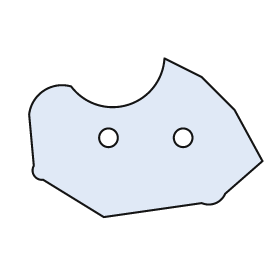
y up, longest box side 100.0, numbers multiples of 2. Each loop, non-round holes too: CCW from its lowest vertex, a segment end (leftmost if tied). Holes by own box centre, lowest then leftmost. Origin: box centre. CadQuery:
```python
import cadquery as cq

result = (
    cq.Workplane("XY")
    .moveTo(-18.0, -34.0)
    .lineTo(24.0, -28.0)
    .threePointArc((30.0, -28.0), (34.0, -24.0))
    .lineTo(50.0, -10.0)
    .lineTo(38.0, 12.0)
    .lineTo(24.0, 26.0)
    .lineTo(8.0, 34.0)
    .threePointArc((-8.0, 14.0), (-32.0, 22.0))
    .threePointArc((-44.0, 20.0), (-50.0, 10.0))
    .lineTo(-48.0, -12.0)
    .threePointArc((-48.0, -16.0), (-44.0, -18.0))
    .close()
    .moveTo(-16.0, 0.0)
    .circle(4.0)
    .moveTo(16.0, 0.0)
    .circle(4.0)
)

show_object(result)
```